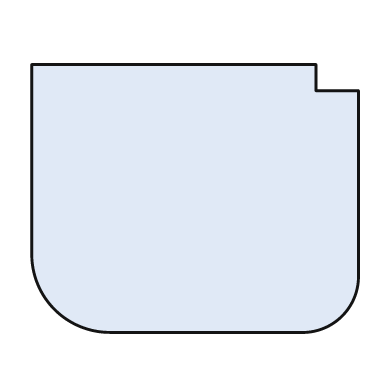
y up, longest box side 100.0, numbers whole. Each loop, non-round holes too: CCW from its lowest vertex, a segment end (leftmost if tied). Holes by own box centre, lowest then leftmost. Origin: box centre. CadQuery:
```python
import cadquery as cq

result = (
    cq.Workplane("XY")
    .moveTo(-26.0, -41.0)
    .lineTo(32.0, -41.0)
    .threePointArc((45.0, -36.0), (50.0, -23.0))
    .lineTo(50.0, 33.0)
    .lineTo(37.0, 33.0)
    .lineTo(37.0, 41.0)
    .lineTo(-50.0, 41.0)
    .lineTo(-50.0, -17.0)
    .threePointArc((-43.0, -34.0), (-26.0, -41.0))
    .close()
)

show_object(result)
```